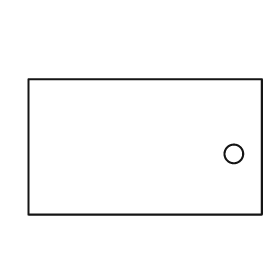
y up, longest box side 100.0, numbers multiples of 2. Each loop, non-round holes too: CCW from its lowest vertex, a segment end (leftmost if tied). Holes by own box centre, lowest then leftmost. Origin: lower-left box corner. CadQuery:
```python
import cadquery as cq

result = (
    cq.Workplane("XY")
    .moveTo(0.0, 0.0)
    .lineTo(100.0, 0.0)
    .lineTo(100.0, 58.0)
    .lineTo(0.0, 58.0)
    .close()
    .moveTo(88.0, 26.0)
    .circle(4.0)
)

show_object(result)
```